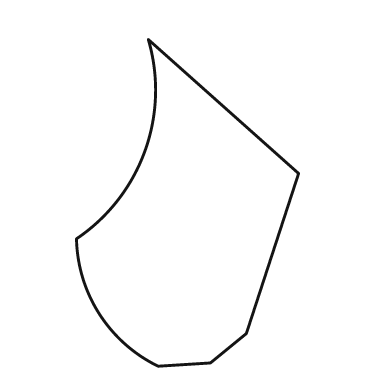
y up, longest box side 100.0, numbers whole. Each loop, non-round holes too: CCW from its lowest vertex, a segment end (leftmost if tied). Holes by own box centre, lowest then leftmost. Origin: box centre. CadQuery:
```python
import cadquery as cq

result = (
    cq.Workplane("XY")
    .moveTo(-9.0, -50.0)
    .lineTo(7.0, -49.0)
    .lineTo(18.0, -40.0)
    .lineTo(34.0, 9.0)
    .lineTo(-12.0, 50.0)
    .threePointArc((-13.0, 16.0), (-34.0, -11.0))
    .threePointArc((-27.0, -34.0), (-9.0, -50.0))
    .close()
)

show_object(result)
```